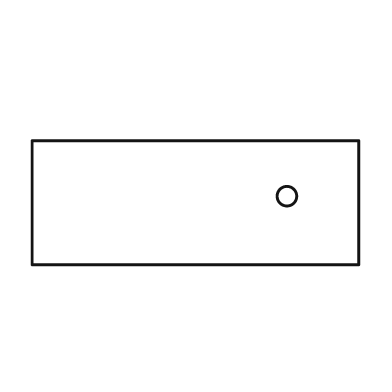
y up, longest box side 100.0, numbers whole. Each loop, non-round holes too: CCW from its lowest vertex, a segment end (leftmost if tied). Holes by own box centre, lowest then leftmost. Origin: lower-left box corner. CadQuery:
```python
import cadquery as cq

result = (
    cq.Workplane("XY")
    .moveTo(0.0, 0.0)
    .lineTo(100.0, 0.0)
    .lineTo(100.0, 38.0)
    .lineTo(0.0, 38.0)
    .close()
    .moveTo(78.0, 21.0)
    .circle(3.0)
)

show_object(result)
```